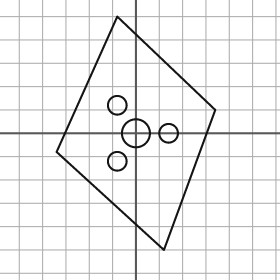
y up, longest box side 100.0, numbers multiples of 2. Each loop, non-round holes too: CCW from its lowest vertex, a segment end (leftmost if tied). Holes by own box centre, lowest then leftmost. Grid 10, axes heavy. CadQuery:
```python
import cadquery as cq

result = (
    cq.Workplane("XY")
    .moveTo(12.0, -50.0)
    .lineTo(34.0, 10.0)
    .lineTo(-8.0, 50.0)
    .lineTo(-34.0, -8.0)
    .close()
    .moveTo(-8.0, -12.0)
    .circle(4.0)
    .moveTo(0.0, 0.0)
    .circle(6.0)
    .moveTo(14.0, 0.0)
    .circle(4.0)
    .moveTo(-8.0, 12.0)
    .circle(4.0)
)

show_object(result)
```